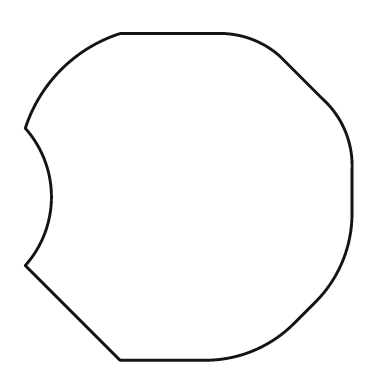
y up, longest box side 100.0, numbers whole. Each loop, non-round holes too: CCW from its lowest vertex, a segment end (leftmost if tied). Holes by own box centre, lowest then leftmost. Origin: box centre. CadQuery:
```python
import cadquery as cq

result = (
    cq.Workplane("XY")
    .moveTo(-21.0, -50.0)
    .lineTo(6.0, -50.0)
    .threePointArc((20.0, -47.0), (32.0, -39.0))
    .lineTo(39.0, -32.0)
    .threePointArc((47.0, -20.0), (50.0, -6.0))
    .lineTo(50.0, 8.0)
    .threePointArc((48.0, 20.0), (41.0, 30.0))
    .lineTo(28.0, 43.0)
    .threePointArc((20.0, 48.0), (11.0, 50.0))
    .lineTo(-21.0, 50.0)
    .threePointArc((-39.0, 39.0), (-50.0, 21.0))
    .threePointArc((-42.0, 0.0), (-50.0, -21.0))
    .close()
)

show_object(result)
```